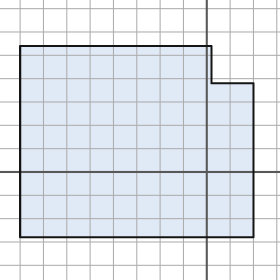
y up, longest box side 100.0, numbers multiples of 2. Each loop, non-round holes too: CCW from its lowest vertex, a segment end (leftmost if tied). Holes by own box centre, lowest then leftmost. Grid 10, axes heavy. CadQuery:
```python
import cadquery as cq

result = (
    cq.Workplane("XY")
    .moveTo(-80.0, -28.0)
    .lineTo(20.0, -28.0)
    .lineTo(20.0, 38.0)
    .lineTo(2.0, 38.0)
    .lineTo(2.0, 54.0)
    .lineTo(-80.0, 54.0)
    .close()
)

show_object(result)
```